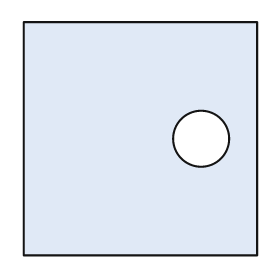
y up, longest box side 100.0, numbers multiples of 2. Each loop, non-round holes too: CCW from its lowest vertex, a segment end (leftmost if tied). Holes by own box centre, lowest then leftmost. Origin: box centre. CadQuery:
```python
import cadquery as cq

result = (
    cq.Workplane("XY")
    .moveTo(-50.0, -50.0)
    .lineTo(50.0, -50.0)
    .lineTo(50.0, 50.0)
    .lineTo(-50.0, 50.0)
    .close()
    .moveTo(26.0, 0.0)
    .circle(12.0)
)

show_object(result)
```